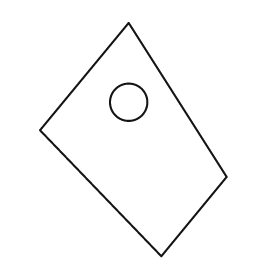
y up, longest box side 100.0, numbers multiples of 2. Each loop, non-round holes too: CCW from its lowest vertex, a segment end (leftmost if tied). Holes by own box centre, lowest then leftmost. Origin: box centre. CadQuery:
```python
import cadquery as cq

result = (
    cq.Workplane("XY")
    .moveTo(12.0, -50.0)
    .lineTo(40.0, -16.0)
    .lineTo(-2.0, 50.0)
    .lineTo(-40.0, 4.0)
    .close()
    .moveTo(-2.0, 16.0)
    .circle(8.0)
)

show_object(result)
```